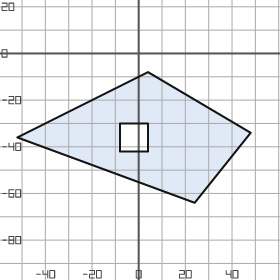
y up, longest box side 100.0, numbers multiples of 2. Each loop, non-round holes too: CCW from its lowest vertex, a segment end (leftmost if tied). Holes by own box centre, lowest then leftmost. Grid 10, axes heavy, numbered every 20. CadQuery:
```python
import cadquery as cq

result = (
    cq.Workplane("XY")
    .moveTo(24.0, -64.0)
    .lineTo(48.0, -34.0)
    .lineTo(4.0, -8.0)
    .lineTo(-52.0, -36.0)
    .close()
    .moveTo(-8.0, -42.0)
    .lineTo(4.0, -42.0)
    .lineTo(4.0, -30.0)
    .lineTo(-8.0, -30.0)
    .close()
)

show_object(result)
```